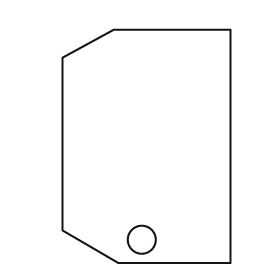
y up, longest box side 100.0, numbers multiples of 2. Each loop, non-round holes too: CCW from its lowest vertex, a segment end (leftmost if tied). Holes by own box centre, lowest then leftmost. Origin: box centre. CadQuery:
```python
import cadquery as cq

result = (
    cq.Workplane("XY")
    .moveTo(-12.0, -50.0)
    .lineTo(36.0, -50.0)
    .lineTo(36.0, 50.0)
    .lineTo(-14.0, 50.0)
    .lineTo(-36.0, 38.0)
    .lineTo(-36.0, -36.0)
    .close()
    .moveTo(-2.0, -40.0)
    .circle(6.0)
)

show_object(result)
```